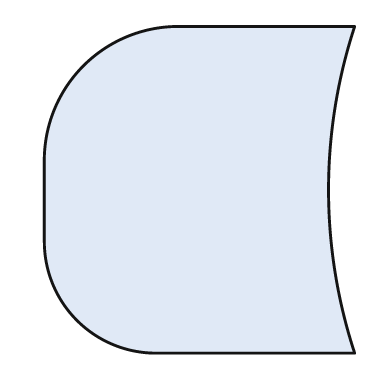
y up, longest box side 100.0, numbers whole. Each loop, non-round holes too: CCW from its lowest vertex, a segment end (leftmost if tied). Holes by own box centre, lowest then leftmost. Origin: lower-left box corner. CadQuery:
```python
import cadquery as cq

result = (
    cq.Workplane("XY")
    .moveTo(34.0, 0.0)
    .lineTo(95.0, 0.0)
    .threePointArc((87.0, 50.0), (95.0, 100.0))
    .lineTo(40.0, 100.0)
    .threePointArc((12.0, 88.0), (0.0, 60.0))
    .lineTo(0.0, 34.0)
    .threePointArc((10.0, 10.0), (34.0, 0.0))
    .close()
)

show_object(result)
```